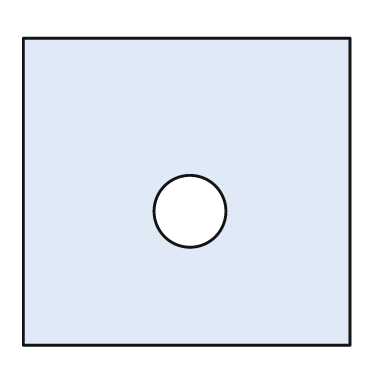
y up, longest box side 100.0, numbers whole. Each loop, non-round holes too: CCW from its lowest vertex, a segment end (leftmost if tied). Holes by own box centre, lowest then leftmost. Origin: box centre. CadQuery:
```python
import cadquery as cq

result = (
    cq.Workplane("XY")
    .moveTo(-50.0, -47.0)
    .lineTo(50.0, -47.0)
    .lineTo(50.0, 47.0)
    .lineTo(-50.0, 47.0)
    .close()
    .moveTo(1.0, -6.0)
    .circle(11.0)
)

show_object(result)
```